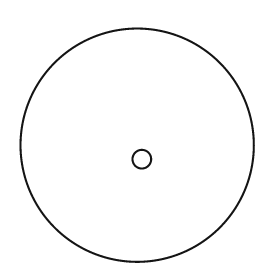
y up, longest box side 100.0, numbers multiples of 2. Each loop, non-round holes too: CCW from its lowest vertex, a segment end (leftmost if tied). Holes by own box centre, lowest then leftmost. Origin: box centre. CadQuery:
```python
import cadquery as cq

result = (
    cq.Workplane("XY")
    .moveTo(0.0, 0.0)
    .circle(50.0)
    .moveTo(2.0, -6.0)
    .circle(4.0)
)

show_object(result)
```